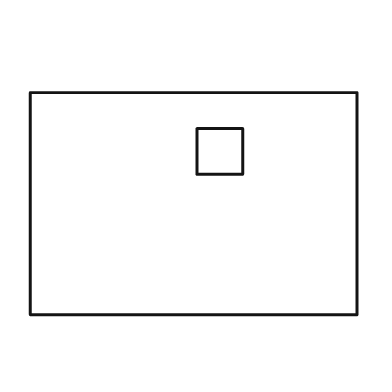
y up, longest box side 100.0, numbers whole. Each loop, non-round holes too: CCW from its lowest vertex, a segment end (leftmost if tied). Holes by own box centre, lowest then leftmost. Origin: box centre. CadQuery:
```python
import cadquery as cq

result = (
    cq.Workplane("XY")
    .moveTo(-50.0, -34.0)
    .lineTo(50.0, -34.0)
    .lineTo(50.0, 34.0)
    .lineTo(-50.0, 34.0)
    .close()
    .moveTo(1.0, 9.0)
    .lineTo(15.0, 9.0)
    .lineTo(15.0, 23.0)
    .lineTo(1.0, 23.0)
    .close()
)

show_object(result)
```